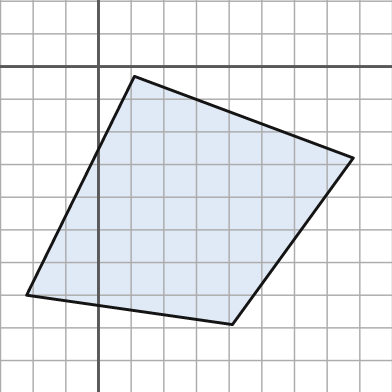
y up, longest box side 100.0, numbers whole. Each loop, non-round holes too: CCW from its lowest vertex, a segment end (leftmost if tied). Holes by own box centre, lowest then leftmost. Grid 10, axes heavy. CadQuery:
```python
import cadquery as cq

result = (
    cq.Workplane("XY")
    .moveTo(41.0, -79.0)
    .lineTo(78.0, -28.0)
    .lineTo(11.0, -3.0)
    .lineTo(-22.0, -70.0)
    .close()
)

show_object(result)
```